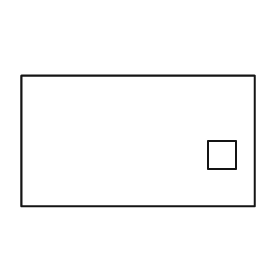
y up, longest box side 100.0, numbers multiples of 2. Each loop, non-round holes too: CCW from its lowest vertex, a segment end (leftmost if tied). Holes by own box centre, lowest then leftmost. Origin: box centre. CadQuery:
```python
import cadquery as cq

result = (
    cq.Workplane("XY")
    .moveTo(-50.0, -28.0)
    .lineTo(50.0, -28.0)
    .lineTo(50.0, 28.0)
    .lineTo(-50.0, 28.0)
    .close()
    .moveTo(30.0, -12.0)
    .lineTo(42.0, -12.0)
    .lineTo(42.0, 0.0)
    .lineTo(30.0, 0.0)
    .close()
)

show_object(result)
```